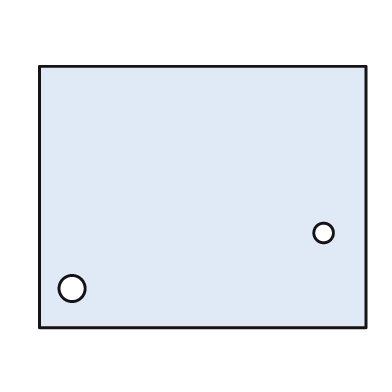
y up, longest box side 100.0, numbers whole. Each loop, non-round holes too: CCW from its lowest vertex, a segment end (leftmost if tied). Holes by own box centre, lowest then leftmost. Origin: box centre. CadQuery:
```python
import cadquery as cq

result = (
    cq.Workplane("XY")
    .moveTo(-50.0, -40.0)
    .lineTo(50.0, -40.0)
    .lineTo(50.0, 40.0)
    .lineTo(-50.0, 40.0)
    .close()
    .moveTo(-40.0, -28.0)
    .circle(4.0)
    .moveTo(37.0, -11.0)
    .circle(3.0)
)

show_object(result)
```